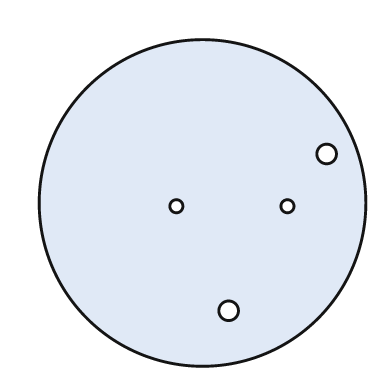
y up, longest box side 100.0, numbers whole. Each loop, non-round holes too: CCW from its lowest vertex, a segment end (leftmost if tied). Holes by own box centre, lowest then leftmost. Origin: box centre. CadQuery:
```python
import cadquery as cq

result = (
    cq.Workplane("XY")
    .moveTo(0.0, 0.0)
    .circle(50.0)
    .moveTo(8.0, -33.0)
    .circle(3.0)
    .moveTo(-8.0, -1.0)
    .circle(2.0)
    .moveTo(26.0, -1.0)
    .circle(2.0)
    .moveTo(38.0, 15.0)
    .circle(3.0)
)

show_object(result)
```